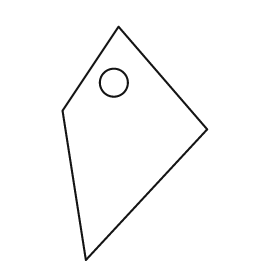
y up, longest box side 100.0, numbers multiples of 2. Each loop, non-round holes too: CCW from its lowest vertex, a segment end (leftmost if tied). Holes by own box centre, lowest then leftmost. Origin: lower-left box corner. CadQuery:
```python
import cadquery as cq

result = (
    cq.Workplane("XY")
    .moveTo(10.0, 0.0)
    .lineTo(62.0, 56.0)
    .lineTo(24.0, 100.0)
    .lineTo(0.0, 64.0)
    .close()
    .moveTo(22.0, 76.0)
    .circle(6.0)
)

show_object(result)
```